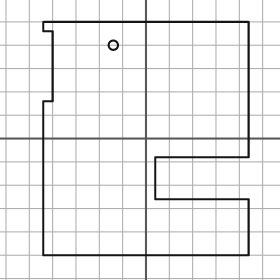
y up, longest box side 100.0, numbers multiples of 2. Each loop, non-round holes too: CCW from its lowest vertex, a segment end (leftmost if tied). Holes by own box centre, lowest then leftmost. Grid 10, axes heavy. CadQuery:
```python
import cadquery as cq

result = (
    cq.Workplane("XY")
    .moveTo(-44.0, -50.0)
    .lineTo(44.0, -50.0)
    .lineTo(44.0, -26.0)
    .lineTo(4.0, -26.0)
    .lineTo(4.0, -8.0)
    .lineTo(44.0, -8.0)
    .lineTo(44.0, 50.0)
    .lineTo(-44.0, 50.0)
    .lineTo(-44.0, 46.0)
    .lineTo(-40.0, 46.0)
    .lineTo(-40.0, 16.0)
    .lineTo(-44.0, 16.0)
    .close()
    .moveTo(-14.0, 40.0)
    .circle(2.0)
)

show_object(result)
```